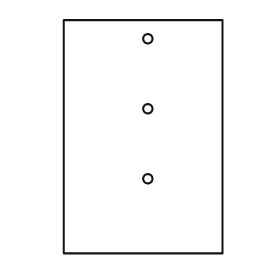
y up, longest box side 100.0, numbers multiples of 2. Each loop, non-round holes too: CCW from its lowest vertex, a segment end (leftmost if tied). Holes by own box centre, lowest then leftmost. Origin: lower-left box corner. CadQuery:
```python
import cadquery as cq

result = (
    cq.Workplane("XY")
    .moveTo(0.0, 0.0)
    .lineTo(68.0, 0.0)
    .lineTo(68.0, 100.0)
    .lineTo(0.0, 100.0)
    .close()
    .moveTo(36.0, 32.0)
    .circle(2.0)
    .moveTo(36.0, 62.0)
    .circle(2.0)
    .moveTo(36.0, 92.0)
    .circle(2.0)
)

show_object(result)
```